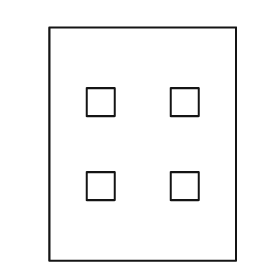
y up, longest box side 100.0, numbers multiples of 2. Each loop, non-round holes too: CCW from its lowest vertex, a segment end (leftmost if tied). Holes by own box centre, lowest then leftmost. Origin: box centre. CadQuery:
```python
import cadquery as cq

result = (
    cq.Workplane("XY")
    .moveTo(-40.0, -50.0)
    .lineTo(40.0, -50.0)
    .lineTo(40.0, 50.0)
    .lineTo(-40.0, 50.0)
    .close()
    .moveTo(-24.0, -24.0)
    .lineTo(-12.0, -24.0)
    .lineTo(-12.0, -12.0)
    .lineTo(-24.0, -12.0)
    .close()
    .moveTo(12.0, -24.0)
    .lineTo(24.0, -24.0)
    .lineTo(24.0, -12.0)
    .lineTo(12.0, -12.0)
    .close()
    .moveTo(-24.0, 12.0)
    .lineTo(-12.0, 12.0)
    .lineTo(-12.0, 24.0)
    .lineTo(-24.0, 24.0)
    .close()
    .moveTo(12.0, 12.0)
    .lineTo(24.0, 12.0)
    .lineTo(24.0, 24.0)
    .lineTo(12.0, 24.0)
    .close()
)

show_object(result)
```